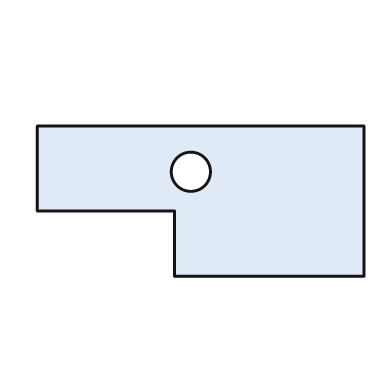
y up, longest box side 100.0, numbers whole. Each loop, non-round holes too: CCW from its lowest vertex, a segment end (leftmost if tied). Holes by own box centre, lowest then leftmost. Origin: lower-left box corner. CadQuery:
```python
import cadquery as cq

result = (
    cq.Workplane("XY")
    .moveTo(42.0, 0.0)
    .lineTo(100.0, 0.0)
    .lineTo(100.0, 46.0)
    .lineTo(0.0, 46.0)
    .lineTo(0.0, 20.0)
    .lineTo(42.0, 20.0)
    .close()
    .moveTo(47.0, 32.0)
    .circle(6.0)
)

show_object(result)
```